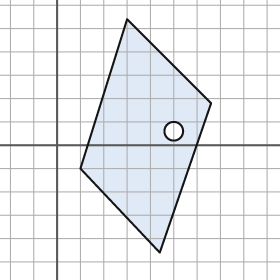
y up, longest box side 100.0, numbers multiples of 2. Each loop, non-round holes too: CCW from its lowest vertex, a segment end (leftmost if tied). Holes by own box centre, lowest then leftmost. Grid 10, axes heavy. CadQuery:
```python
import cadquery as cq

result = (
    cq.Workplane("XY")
    .moveTo(44.0, -46.0)
    .lineTo(66.0, 18.0)
    .lineTo(30.0, 54.0)
    .lineTo(10.0, -10.0)
    .close()
    .moveTo(50.0, 6.0)
    .circle(4.0)
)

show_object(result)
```